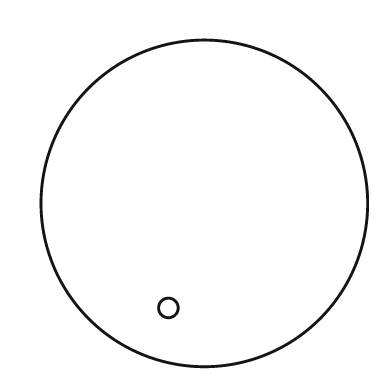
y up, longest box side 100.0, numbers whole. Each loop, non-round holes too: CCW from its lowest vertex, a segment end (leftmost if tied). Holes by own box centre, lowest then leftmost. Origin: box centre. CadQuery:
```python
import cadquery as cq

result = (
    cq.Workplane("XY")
    .moveTo(0.0, 0.0)
    .circle(50.0)
    .moveTo(-11.0, -32.0)
    .circle(3.0)
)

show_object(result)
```